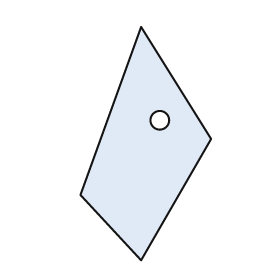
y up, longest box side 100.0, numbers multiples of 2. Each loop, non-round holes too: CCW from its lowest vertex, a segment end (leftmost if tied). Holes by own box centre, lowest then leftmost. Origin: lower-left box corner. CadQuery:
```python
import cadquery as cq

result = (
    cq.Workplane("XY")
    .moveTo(26.0, 0.0)
    .lineTo(56.0, 52.0)
    .lineTo(26.0, 100.0)
    .lineTo(0.0, 28.0)
    .close()
    .moveTo(34.0, 60.0)
    .circle(4.0)
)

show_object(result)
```